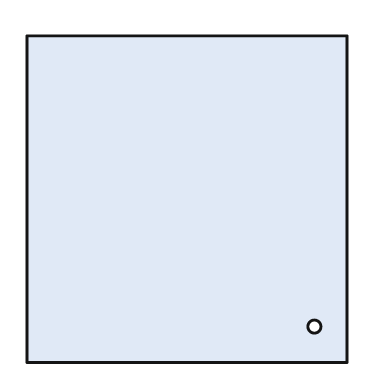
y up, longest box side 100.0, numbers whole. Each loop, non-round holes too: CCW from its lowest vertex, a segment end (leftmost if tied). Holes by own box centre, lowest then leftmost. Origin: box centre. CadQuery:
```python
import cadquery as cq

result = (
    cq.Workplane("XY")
    .moveTo(-49.0, -50.0)
    .lineTo(49.0, -50.0)
    .lineTo(49.0, 50.0)
    .lineTo(-49.0, 50.0)
    .close()
    .moveTo(39.0, -39.0)
    .circle(2.0)
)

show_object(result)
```